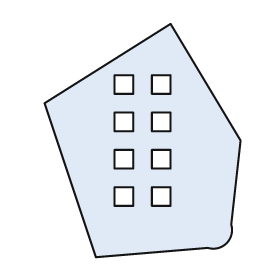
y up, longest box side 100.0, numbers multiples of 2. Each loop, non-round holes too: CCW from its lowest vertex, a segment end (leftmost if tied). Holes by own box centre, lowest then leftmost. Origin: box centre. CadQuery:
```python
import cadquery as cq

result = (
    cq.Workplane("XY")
    .moveTo(-20.0, -50.0)
    .lineTo(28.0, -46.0)
    .threePointArc((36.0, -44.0), (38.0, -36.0))
    .lineTo(42.0, 0.0)
    .lineTo(12.0, 50.0)
    .lineTo(-42.0, 16.0)
    .close()
    .moveTo(-12.0, -28.0)
    .lineTo(-4.0, -28.0)
    .lineTo(-4.0, -20.0)
    .lineTo(-12.0, -20.0)
    .close()
    .moveTo(4.0, -28.0)
    .lineTo(12.0, -28.0)
    .lineTo(12.0, -20.0)
    .lineTo(4.0, -20.0)
    .close()
    .moveTo(-12.0, -12.0)
    .lineTo(-4.0, -12.0)
    .lineTo(-4.0, -4.0)
    .lineTo(-12.0, -4.0)
    .close()
    .moveTo(4.0, -12.0)
    .lineTo(12.0, -12.0)
    .lineTo(12.0, -4.0)
    .lineTo(4.0, -4.0)
    .close()
    .moveTo(-12.0, 4.0)
    .lineTo(-4.0, 4.0)
    .lineTo(-4.0, 12.0)
    .lineTo(-12.0, 12.0)
    .close()
    .moveTo(4.0, 4.0)
    .lineTo(12.0, 4.0)
    .lineTo(12.0, 12.0)
    .lineTo(4.0, 12.0)
    .close()
    .moveTo(-12.0, 20.0)
    .lineTo(-4.0, 20.0)
    .lineTo(-4.0, 28.0)
    .lineTo(-12.0, 28.0)
    .close()
    .moveTo(4.0, 20.0)
    .lineTo(12.0, 20.0)
    .lineTo(12.0, 28.0)
    .lineTo(4.0, 28.0)
    .close()
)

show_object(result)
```